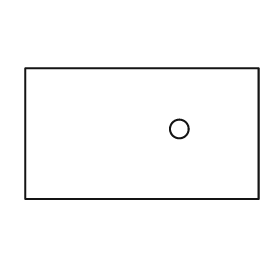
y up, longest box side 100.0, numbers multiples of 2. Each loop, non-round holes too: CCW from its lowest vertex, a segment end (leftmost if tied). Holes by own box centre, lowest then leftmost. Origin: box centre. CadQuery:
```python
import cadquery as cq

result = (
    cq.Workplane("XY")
    .moveTo(-50.0, -28.0)
    .lineTo(50.0, -28.0)
    .lineTo(50.0, 28.0)
    .lineTo(-50.0, 28.0)
    .close()
    .moveTo(16.0, 2.0)
    .circle(4.0)
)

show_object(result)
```